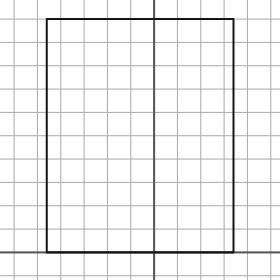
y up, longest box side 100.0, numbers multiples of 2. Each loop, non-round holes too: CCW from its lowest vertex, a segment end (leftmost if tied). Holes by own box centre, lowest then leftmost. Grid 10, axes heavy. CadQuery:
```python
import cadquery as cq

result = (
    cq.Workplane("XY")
    .moveTo(-46.0, 0.0)
    .lineTo(34.0, 0.0)
    .lineTo(34.0, 100.0)
    .lineTo(-46.0, 100.0)
    .close()
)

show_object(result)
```